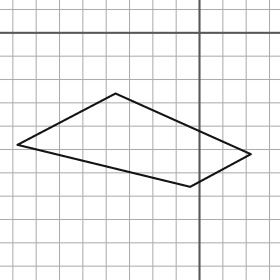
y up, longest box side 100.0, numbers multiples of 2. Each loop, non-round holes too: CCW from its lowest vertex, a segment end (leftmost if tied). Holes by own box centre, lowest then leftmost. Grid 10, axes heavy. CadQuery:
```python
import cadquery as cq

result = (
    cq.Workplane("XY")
    .moveTo(-4.0, -66.0)
    .lineTo(22.0, -52.0)
    .lineTo(-36.0, -26.0)
    .lineTo(-78.0, -48.0)
    .close()
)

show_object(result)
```